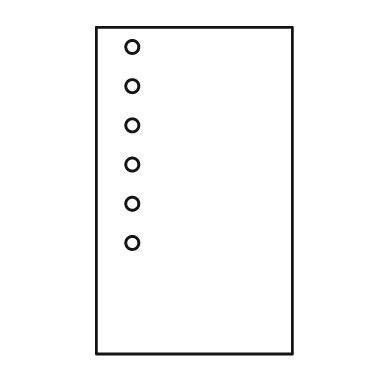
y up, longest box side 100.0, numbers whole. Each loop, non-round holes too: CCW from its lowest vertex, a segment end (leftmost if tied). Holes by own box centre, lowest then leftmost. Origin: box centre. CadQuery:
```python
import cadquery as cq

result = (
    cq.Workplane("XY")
    .moveTo(-30.0, -50.0)
    .lineTo(30.0, -50.0)
    .lineTo(30.0, 50.0)
    .lineTo(-30.0, 50.0)
    .close()
    .moveTo(-19.0, -16.0)
    .circle(2.0)
    .moveTo(-19.0, -4.0)
    .circle(2.0)
    .moveTo(-19.0, 8.0)
    .circle(2.0)
    .moveTo(-19.0, 20.0)
    .circle(2.0)
    .moveTo(-19.0, 32.0)
    .circle(2.0)
    .moveTo(-19.0, 44.0)
    .circle(2.0)
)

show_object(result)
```